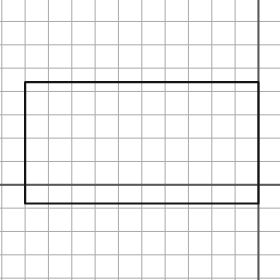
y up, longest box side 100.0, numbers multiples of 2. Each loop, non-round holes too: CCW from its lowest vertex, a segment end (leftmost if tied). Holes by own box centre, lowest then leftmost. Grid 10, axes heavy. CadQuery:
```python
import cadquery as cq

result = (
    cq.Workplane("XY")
    .moveTo(-100.0, -8.0)
    .lineTo(0.0, -8.0)
    .lineTo(0.0, 44.0)
    .lineTo(-100.0, 44.0)
    .close()
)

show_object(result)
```